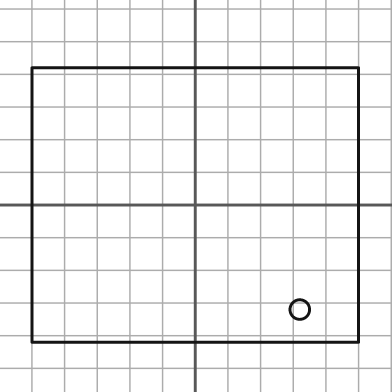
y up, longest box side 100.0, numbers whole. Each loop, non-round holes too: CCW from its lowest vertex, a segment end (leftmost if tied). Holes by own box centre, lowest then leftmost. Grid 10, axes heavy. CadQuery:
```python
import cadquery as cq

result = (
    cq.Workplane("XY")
    .moveTo(-50.0, -42.0)
    .lineTo(50.0, -42.0)
    .lineTo(50.0, 42.0)
    .lineTo(-50.0, 42.0)
    .close()
    .moveTo(32.0, -32.0)
    .circle(3.0)
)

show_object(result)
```